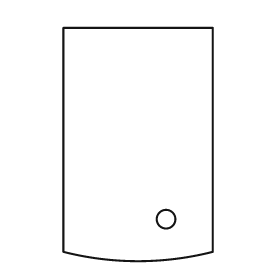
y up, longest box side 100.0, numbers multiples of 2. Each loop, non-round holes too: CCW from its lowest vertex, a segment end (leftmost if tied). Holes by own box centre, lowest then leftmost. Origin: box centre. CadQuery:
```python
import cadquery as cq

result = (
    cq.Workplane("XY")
    .moveTo(-32.0, -46.0)
    .threePointArc((0.0, -50.0), (32.0, -46.0))
    .lineTo(32.0, 50.0)
    .lineTo(-32.0, 50.0)
    .close()
    .moveTo(12.0, -32.0)
    .circle(4.0)
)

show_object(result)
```